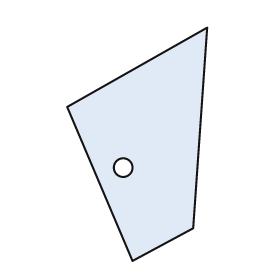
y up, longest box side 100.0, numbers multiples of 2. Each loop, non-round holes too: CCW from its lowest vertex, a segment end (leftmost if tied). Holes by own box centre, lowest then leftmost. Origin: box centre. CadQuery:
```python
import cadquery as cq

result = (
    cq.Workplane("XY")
    .moveTo(-2.0, -50.0)
    .lineTo(24.0, -36.0)
    .lineTo(30.0, 50.0)
    .lineTo(-30.0, 16.0)
    .close()
    .moveTo(-6.0, -10.0)
    .circle(4.0)
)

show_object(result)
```